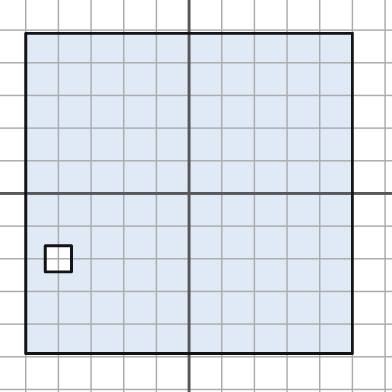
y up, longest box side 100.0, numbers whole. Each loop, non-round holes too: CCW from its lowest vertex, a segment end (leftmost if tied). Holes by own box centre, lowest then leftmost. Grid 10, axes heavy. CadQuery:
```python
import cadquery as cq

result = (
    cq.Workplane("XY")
    .moveTo(-50.0, -49.0)
    .lineTo(50.0, -49.0)
    .lineTo(50.0, 49.0)
    .lineTo(-50.0, 49.0)
    .close()
    .moveTo(-44.0, -24.0)
    .lineTo(-36.0, -24.0)
    .lineTo(-36.0, -16.0)
    .lineTo(-44.0, -16.0)
    .close()
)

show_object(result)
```